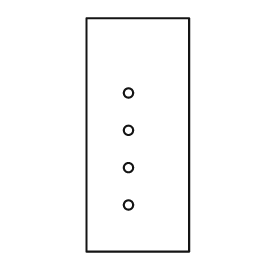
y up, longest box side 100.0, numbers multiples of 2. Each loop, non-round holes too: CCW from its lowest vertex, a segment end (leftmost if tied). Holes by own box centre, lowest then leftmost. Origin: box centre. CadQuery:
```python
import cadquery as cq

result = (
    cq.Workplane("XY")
    .moveTo(-22.0, -50.0)
    .lineTo(22.0, -50.0)
    .lineTo(22.0, 50.0)
    .lineTo(-22.0, 50.0)
    .close()
    .moveTo(-4.0, -30.0)
    .circle(2.0)
    .moveTo(-4.0, -14.0)
    .circle(2.0)
    .moveTo(-4.0, 2.0)
    .circle(2.0)
    .moveTo(-4.0, 18.0)
    .circle(2.0)
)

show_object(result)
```